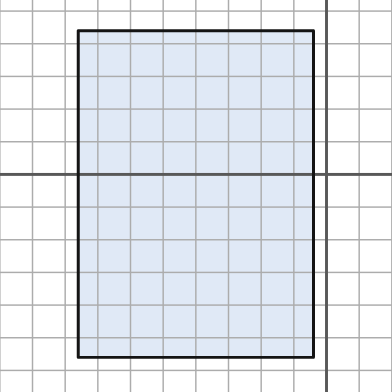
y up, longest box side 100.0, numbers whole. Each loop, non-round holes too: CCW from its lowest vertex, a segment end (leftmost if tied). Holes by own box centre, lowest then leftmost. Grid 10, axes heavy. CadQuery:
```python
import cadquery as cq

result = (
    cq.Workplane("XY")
    .moveTo(-76.0, -56.0)
    .lineTo(-4.0, -56.0)
    .lineTo(-4.0, 44.0)
    .lineTo(-76.0, 44.0)
    .close()
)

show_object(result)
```